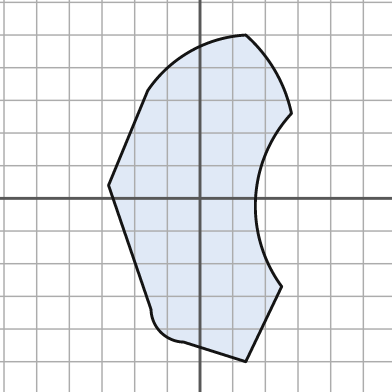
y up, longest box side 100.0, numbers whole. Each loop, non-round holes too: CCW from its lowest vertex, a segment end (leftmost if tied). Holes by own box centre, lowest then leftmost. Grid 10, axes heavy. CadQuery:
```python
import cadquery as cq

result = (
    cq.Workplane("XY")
    .moveTo(14.0, -50.0)
    .lineTo(25.0, -27.0)
    .threePointArc((17.0, 0.0), (28.0, 26.0))
    .threePointArc((23.0, 39.0), (14.0, 50.0))
    .threePointArc((-3.0, 45.0), (-16.0, 33.0))
    .lineTo(-28.0, 4.0)
    .lineTo(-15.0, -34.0)
    .threePointArc((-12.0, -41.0), (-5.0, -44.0))
    .close()
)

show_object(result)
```